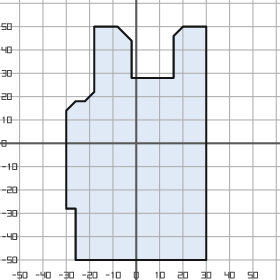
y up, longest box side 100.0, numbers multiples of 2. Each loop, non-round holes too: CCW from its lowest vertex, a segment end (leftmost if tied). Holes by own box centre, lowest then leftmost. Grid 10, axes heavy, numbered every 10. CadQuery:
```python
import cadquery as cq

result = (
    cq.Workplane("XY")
    .moveTo(-26.0, -50.0)
    .lineTo(30.0, -50.0)
    .lineTo(30.0, 50.0)
    .lineTo(20.0, 50.0)
    .lineTo(16.0, 46.0)
    .lineTo(16.0, 28.0)
    .lineTo(-2.0, 28.0)
    .lineTo(-2.0, 44.0)
    .lineTo(-8.0, 50.0)
    .lineTo(-18.0, 50.0)
    .lineTo(-18.0, 22.0)
    .lineTo(-22.0, 18.0)
    .lineTo(-26.0, 18.0)
    .lineTo(-30.0, 14.0)
    .lineTo(-30.0, -28.0)
    .lineTo(-26.0, -28.0)
    .close()
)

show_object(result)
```